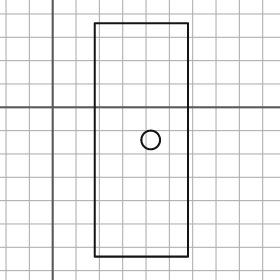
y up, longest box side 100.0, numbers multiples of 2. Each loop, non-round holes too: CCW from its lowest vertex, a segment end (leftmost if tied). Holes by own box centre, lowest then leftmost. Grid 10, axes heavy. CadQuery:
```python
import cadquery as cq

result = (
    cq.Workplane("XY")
    .moveTo(18.0, -64.0)
    .lineTo(58.0, -64.0)
    .lineTo(58.0, 36.0)
    .lineTo(18.0, 36.0)
    .close()
    .moveTo(42.0, -14.0)
    .circle(4.0)
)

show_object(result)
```